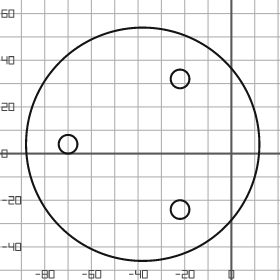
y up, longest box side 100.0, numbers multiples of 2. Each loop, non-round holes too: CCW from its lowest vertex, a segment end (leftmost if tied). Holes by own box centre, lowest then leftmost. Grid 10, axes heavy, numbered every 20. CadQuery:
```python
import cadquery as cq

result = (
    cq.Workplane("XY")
    .moveTo(-38.0, 4.0)
    .circle(50.0)
    .moveTo(-22.0, -24.0)
    .circle(4.0)
    .moveTo(-70.0, 4.0)
    .circle(4.0)
    .moveTo(-22.0, 32.0)
    .circle(4.0)
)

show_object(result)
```